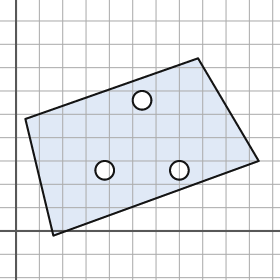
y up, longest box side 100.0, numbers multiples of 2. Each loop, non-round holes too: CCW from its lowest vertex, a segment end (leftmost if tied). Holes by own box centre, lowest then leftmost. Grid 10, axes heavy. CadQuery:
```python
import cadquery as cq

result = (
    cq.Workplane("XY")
    .moveTo(16.0, -2.0)
    .lineTo(104.0, 30.0)
    .lineTo(78.0, 74.0)
    .lineTo(4.0, 48.0)
    .close()
    .moveTo(38.0, 26.0)
    .circle(4.0)
    .moveTo(70.0, 26.0)
    .circle(4.0)
    .moveTo(54.0, 56.0)
    .circle(4.0)
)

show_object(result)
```